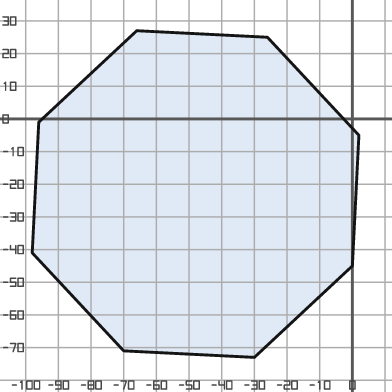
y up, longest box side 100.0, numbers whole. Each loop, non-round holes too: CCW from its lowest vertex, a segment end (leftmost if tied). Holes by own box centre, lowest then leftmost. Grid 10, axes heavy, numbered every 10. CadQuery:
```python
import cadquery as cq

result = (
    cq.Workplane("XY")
    .moveTo(-30.0, -73.0)
    .lineTo(0.0, -45.0)
    .lineTo(2.0, -5.0)
    .lineTo(-26.0, 25.0)
    .lineTo(-66.0, 27.0)
    .lineTo(-96.0, -1.0)
    .lineTo(-98.0, -41.0)
    .lineTo(-70.0, -71.0)
    .close()
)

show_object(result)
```